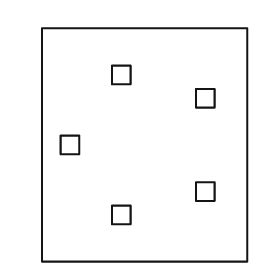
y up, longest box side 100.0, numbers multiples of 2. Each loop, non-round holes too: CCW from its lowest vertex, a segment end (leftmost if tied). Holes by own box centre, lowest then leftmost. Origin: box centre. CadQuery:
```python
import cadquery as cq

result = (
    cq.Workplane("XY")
    .moveTo(-44.0, -50.0)
    .lineTo(44.0, -50.0)
    .lineTo(44.0, 50.0)
    .lineTo(-44.0, 50.0)
    .close()
    .moveTo(-14.0, -34.0)
    .lineTo(-6.0, -34.0)
    .lineTo(-6.0, -26.0)
    .lineTo(-14.0, -26.0)
    .close()
    .moveTo(22.0, -24.0)
    .lineTo(30.0, -24.0)
    .lineTo(30.0, -16.0)
    .lineTo(22.0, -16.0)
    .close()
    .moveTo(-36.0, -4.0)
    .lineTo(-28.0, -4.0)
    .lineTo(-28.0, 4.0)
    .lineTo(-36.0, 4.0)
    .close()
    .moveTo(22.0, 16.0)
    .lineTo(30.0, 16.0)
    .lineTo(30.0, 24.0)
    .lineTo(22.0, 24.0)
    .close()
    .moveTo(-14.0, 26.0)
    .lineTo(-6.0, 26.0)
    .lineTo(-6.0, 34.0)
    .lineTo(-14.0, 34.0)
    .close()
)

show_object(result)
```